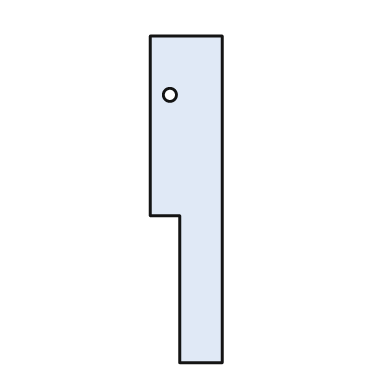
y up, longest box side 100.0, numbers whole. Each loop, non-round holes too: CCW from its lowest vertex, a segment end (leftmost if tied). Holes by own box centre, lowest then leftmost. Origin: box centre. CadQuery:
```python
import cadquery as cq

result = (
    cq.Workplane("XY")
    .moveTo(-2.0, -50.0)
    .lineTo(11.0, -50.0)
    .lineTo(11.0, 50.0)
    .lineTo(-11.0, 50.0)
    .lineTo(-11.0, -5.0)
    .lineTo(-2.0, -5.0)
    .close()
    .moveTo(-5.0, 32.0)
    .circle(2.0)
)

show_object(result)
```